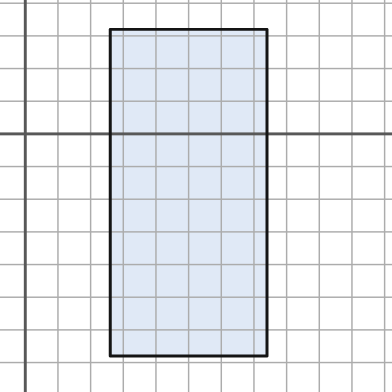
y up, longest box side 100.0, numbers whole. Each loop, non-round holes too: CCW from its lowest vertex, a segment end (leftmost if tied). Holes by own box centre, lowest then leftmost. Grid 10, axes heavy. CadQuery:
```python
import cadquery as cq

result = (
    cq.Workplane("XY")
    .moveTo(26.0, -68.0)
    .lineTo(74.0, -68.0)
    .lineTo(74.0, 32.0)
    .lineTo(26.0, 32.0)
    .close()
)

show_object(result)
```